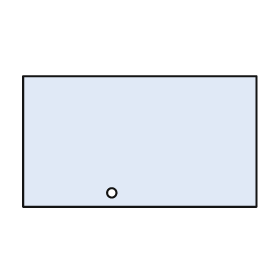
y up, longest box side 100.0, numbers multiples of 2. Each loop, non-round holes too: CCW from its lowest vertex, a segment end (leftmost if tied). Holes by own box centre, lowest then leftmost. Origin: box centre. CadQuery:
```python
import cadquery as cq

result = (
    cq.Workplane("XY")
    .moveTo(-50.0, -28.0)
    .lineTo(50.0, -28.0)
    .lineTo(50.0, 28.0)
    .lineTo(-50.0, 28.0)
    .close()
    .moveTo(-12.0, -22.0)
    .circle(2.0)
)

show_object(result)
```